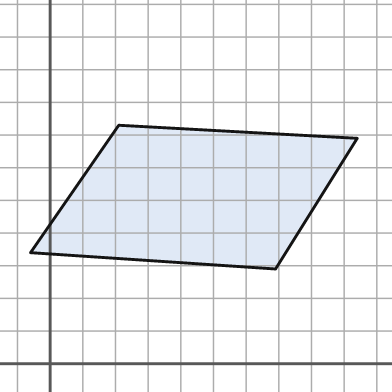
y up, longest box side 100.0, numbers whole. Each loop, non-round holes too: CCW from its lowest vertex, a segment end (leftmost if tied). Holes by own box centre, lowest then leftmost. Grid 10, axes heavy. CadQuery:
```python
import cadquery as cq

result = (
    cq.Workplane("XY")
    .moveTo(69.0, 29.0)
    .lineTo(94.0, 69.0)
    .lineTo(21.0, 73.0)
    .lineTo(-6.0, 34.0)
    .close()
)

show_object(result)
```